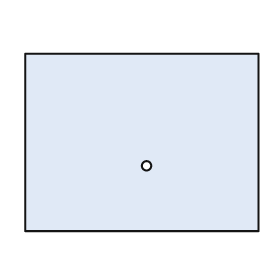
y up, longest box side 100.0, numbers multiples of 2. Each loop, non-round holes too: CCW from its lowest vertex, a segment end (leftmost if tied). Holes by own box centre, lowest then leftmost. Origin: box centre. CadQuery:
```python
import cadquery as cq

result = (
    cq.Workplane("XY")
    .moveTo(-50.0, -38.0)
    .lineTo(50.0, -38.0)
    .lineTo(50.0, 38.0)
    .lineTo(-50.0, 38.0)
    .close()
    .moveTo(2.0, -10.0)
    .circle(2.0)
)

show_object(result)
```